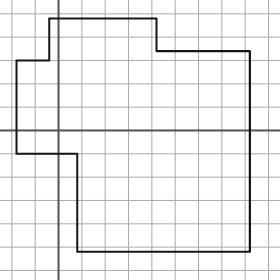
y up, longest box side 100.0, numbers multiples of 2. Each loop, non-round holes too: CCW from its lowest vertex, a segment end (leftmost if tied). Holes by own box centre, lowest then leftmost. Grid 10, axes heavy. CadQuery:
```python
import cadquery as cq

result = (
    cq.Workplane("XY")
    .moveTo(8.0, -52.0)
    .lineTo(82.0, -52.0)
    .lineTo(82.0, 34.0)
    .lineTo(42.0, 34.0)
    .lineTo(42.0, 48.0)
    .lineTo(-4.0, 48.0)
    .lineTo(-4.0, 30.0)
    .lineTo(-18.0, 30.0)
    .lineTo(-18.0, -10.0)
    .lineTo(8.0, -10.0)
    .close()
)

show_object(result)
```